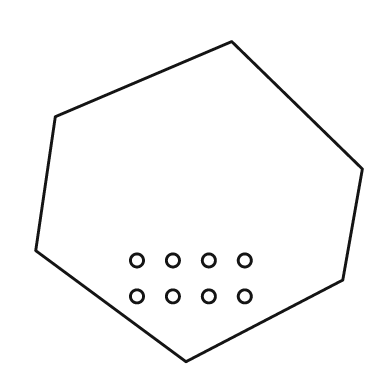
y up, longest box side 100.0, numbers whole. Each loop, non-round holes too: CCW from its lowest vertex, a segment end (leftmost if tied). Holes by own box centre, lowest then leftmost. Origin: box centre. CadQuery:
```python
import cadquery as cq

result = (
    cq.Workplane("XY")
    .moveTo(-4.0, -49.0)
    .lineTo(44.0, -24.0)
    .lineTo(50.0, 10.0)
    .lineTo(10.0, 49.0)
    .lineTo(-44.0, 26.0)
    .lineTo(-50.0, -15.0)
    .close()
    .moveTo(-19.0, -29.0)
    .circle(2.0)
    .moveTo(-8.0, -29.0)
    .circle(2.0)
    .moveTo(3.0, -29.0)
    .circle(2.0)
    .moveTo(14.0, -29.0)
    .circle(2.0)
    .moveTo(-19.0, -18.0)
    .circle(2.0)
    .moveTo(-8.0, -18.0)
    .circle(2.0)
    .moveTo(3.0, -18.0)
    .circle(2.0)
    .moveTo(14.0, -18.0)
    .circle(2.0)
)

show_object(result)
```